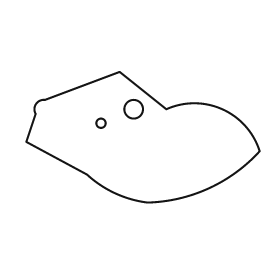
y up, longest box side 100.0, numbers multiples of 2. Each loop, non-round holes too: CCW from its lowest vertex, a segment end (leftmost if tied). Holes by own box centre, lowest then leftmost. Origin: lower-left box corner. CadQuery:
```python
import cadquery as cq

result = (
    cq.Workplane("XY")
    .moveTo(52.0, 0.0)
    .threePointArc((78.0, 6.0), (100.0, 22.0))
    .threePointArc((84.0, 40.0), (60.0, 40.0))
    .lineTo(40.0, 56.0)
    .lineTo(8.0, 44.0)
    .threePointArc((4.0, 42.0), (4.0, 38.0))
    .lineTo(0.0, 26.0)
    .lineTo(26.0, 12.0)
    .threePointArc((38.0, 4.0), (52.0, 0.0))
    .close()
    .moveTo(32.0, 34.0)
    .circle(2.0)
    .moveTo(46.0, 40.0)
    .circle(4.0)
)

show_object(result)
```